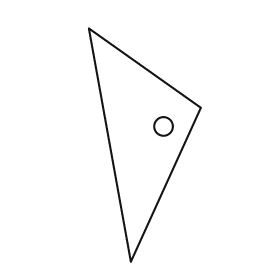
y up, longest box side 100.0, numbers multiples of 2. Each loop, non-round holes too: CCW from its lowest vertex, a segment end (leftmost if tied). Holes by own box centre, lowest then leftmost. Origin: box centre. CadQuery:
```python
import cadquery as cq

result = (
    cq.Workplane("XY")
    .moveTo(-6.0, -50.0)
    .lineTo(24.0, 16.0)
    .lineTo(-24.0, 50.0)
    .close()
    .moveTo(8.0, 8.0)
    .circle(4.0)
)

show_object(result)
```